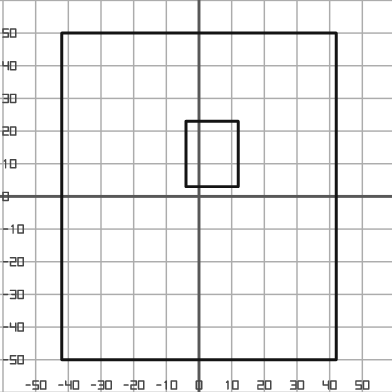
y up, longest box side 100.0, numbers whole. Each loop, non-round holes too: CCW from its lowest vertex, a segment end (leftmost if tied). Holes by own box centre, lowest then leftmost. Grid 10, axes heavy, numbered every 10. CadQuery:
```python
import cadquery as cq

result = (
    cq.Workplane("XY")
    .moveTo(-42.0, -50.0)
    .lineTo(42.0, -50.0)
    .lineTo(42.0, 50.0)
    .lineTo(-42.0, 50.0)
    .close()
    .moveTo(-4.0, 3.0)
    .lineTo(12.0, 3.0)
    .lineTo(12.0, 23.0)
    .lineTo(-4.0, 23.0)
    .close()
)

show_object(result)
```